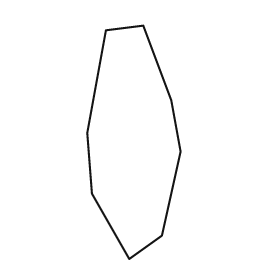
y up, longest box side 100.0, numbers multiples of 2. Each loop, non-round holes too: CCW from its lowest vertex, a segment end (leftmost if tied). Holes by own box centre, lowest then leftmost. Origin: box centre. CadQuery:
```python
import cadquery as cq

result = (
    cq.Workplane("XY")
    .moveTo(-2.0, -50.0)
    .lineTo(12.0, -40.0)
    .lineTo(20.0, -4.0)
    .lineTo(16.0, 18.0)
    .lineTo(4.0, 50.0)
    .lineTo(-12.0, 48.0)
    .lineTo(-20.0, 4.0)
    .lineTo(-18.0, -22.0)
    .close()
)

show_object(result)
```